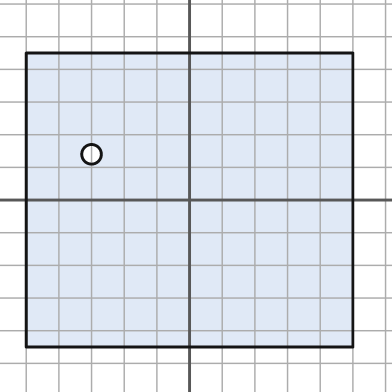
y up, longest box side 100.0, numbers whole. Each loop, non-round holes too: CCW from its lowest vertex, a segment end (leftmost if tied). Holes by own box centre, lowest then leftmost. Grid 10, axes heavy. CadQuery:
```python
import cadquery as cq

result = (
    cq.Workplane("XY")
    .moveTo(-50.0, -45.0)
    .lineTo(50.0, -45.0)
    .lineTo(50.0, 45.0)
    .lineTo(-50.0, 45.0)
    .close()
    .moveTo(-30.0, 14.0)
    .circle(3.0)
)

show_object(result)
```